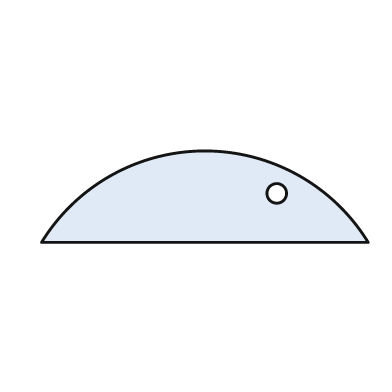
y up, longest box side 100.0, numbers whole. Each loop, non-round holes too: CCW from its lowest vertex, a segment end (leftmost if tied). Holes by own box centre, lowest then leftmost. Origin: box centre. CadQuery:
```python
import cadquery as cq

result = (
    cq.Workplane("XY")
    .moveTo(-50.0, -14.0)
    .lineTo(50.0, -14.0)
    .threePointArc((0.0, 14.0), (-50.0, -14.0))
    .close()
    .moveTo(22.0, 1.0)
    .circle(3.0)
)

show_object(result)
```